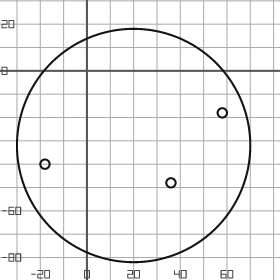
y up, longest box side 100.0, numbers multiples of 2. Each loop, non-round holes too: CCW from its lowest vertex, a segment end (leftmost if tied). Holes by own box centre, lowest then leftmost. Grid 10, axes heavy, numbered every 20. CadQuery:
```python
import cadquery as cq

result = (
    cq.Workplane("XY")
    .moveTo(20.0, -32.0)
    .circle(50.0)
    .moveTo(36.0, -48.0)
    .circle(2.0)
    .moveTo(-18.0, -40.0)
    .circle(2.0)
    .moveTo(58.0, -18.0)
    .circle(2.0)
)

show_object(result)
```